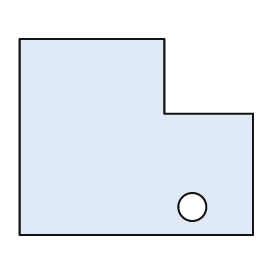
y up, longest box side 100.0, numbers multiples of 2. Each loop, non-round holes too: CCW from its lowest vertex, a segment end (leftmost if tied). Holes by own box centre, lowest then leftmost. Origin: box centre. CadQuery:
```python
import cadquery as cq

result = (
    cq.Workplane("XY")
    .moveTo(-50.0, -42.0)
    .lineTo(50.0, -42.0)
    .lineTo(50.0, 10.0)
    .lineTo(12.0, 10.0)
    .lineTo(12.0, 42.0)
    .lineTo(-50.0, 42.0)
    .close()
    .moveTo(24.0, -30.0)
    .circle(6.0)
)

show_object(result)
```